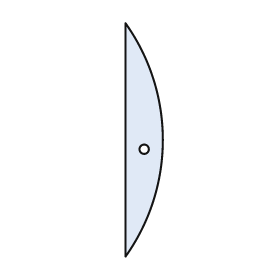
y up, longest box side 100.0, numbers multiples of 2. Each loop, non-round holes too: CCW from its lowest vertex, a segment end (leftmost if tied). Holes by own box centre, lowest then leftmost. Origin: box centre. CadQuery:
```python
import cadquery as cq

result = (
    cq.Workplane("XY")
    .moveTo(-8.0, -50.0)
    .threePointArc((8.0, 0.0), (-8.0, 50.0))
    .close()
    .moveTo(0.0, -4.0)
    .circle(2.0)
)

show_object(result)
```